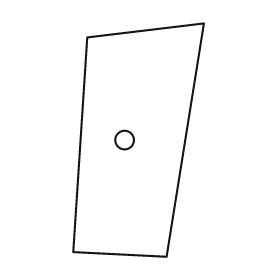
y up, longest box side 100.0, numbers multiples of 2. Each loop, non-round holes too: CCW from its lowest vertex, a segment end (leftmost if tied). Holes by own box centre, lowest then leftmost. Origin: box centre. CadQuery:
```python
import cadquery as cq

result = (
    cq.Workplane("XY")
    .moveTo(12.0, -50.0)
    .lineTo(28.0, 50.0)
    .lineTo(-22.0, 44.0)
    .lineTo(-28.0, -48.0)
    .close()
    .moveTo(-6.0, 0.0)
    .circle(4.0)
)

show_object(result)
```